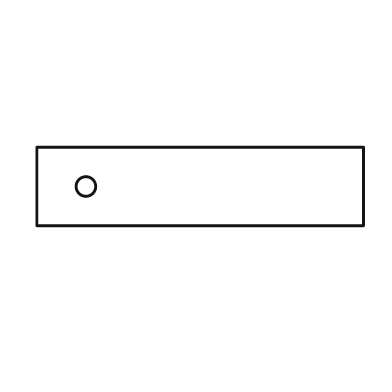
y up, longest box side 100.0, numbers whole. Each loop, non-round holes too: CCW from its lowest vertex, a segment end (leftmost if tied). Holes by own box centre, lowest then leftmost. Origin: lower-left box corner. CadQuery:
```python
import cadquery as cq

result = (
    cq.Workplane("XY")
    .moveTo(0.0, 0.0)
    .lineTo(100.0, 0.0)
    .lineTo(100.0, 24.0)
    .lineTo(0.0, 24.0)
    .close()
    .moveTo(15.0, 12.0)
    .circle(3.0)
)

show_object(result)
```